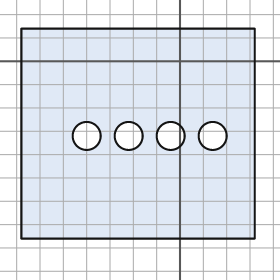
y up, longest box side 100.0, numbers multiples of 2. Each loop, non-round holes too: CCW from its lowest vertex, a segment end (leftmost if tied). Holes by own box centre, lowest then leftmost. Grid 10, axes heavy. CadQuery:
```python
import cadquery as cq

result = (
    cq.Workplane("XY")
    .moveTo(-68.0, -76.0)
    .lineTo(32.0, -76.0)
    .lineTo(32.0, 14.0)
    .lineTo(-68.0, 14.0)
    .close()
    .moveTo(-40.0, -32.0)
    .circle(6.0)
    .moveTo(-22.0, -32.0)
    .circle(6.0)
    .moveTo(-4.0, -32.0)
    .circle(6.0)
    .moveTo(14.0, -32.0)
    .circle(6.0)
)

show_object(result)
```